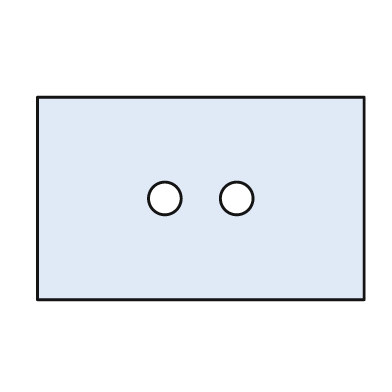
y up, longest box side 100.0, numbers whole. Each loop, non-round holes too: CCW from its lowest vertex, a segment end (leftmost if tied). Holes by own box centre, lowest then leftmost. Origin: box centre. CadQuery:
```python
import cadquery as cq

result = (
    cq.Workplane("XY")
    .moveTo(-50.0, -31.0)
    .lineTo(50.0, -31.0)
    .lineTo(50.0, 31.0)
    .lineTo(-50.0, 31.0)
    .close()
    .moveTo(-11.0, 0.0)
    .circle(5.0)
    .moveTo(11.0, 0.0)
    .circle(5.0)
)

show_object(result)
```